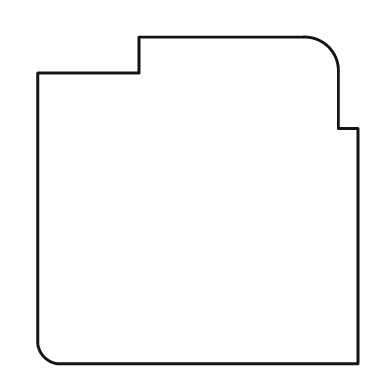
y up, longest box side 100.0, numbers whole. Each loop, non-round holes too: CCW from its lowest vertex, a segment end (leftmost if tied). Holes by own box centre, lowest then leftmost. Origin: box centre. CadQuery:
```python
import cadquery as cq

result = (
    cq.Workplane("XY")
    .moveTo(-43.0, -50.0)
    .lineTo(49.0, -50.0)
    .lineTo(49.0, 22.0)
    .lineTo(43.0, 22.0)
    .lineTo(43.0, 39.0)
    .threePointArc((40.0, 47.0), (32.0, 50.0))
    .lineTo(-18.0, 50.0)
    .lineTo(-18.0, 39.0)
    .lineTo(-49.0, 39.0)
    .lineTo(-49.0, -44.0)
    .threePointArc((-47.0, -48.0), (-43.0, -50.0))
    .close()
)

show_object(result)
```